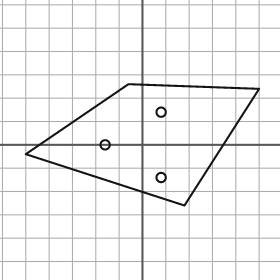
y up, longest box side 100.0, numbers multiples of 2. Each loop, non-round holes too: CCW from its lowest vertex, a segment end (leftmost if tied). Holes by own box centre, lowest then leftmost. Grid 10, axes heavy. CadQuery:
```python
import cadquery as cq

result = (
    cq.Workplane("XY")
    .moveTo(18.0, -26.0)
    .lineTo(50.0, 24.0)
    .lineTo(-6.0, 26.0)
    .lineTo(-50.0, -4.0)
    .close()
    .moveTo(8.0, -14.0)
    .circle(2.0)
    .moveTo(-16.0, 0.0)
    .circle(2.0)
    .moveTo(8.0, 14.0)
    .circle(2.0)
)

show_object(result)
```